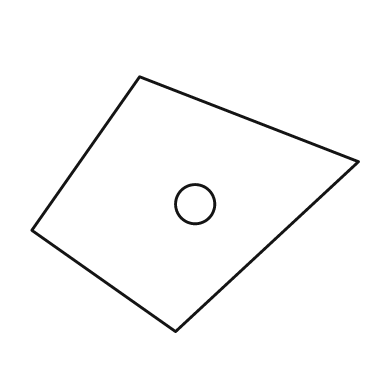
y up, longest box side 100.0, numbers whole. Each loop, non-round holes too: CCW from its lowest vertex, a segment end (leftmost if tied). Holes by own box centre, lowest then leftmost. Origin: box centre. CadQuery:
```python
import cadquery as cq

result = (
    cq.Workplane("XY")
    .moveTo(-6.0, -39.0)
    .lineTo(50.0, 13.0)
    .lineTo(-17.0, 39.0)
    .lineTo(-50.0, -8.0)
    .close()
    .moveTo(0.0, 0.0)
    .circle(6.0)
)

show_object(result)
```